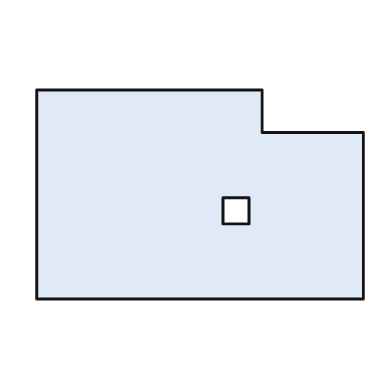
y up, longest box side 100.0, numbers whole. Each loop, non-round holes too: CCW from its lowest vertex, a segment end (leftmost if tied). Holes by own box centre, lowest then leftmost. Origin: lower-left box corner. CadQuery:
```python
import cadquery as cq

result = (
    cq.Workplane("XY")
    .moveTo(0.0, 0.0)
    .lineTo(100.0, 0.0)
    .lineTo(100.0, 51.0)
    .lineTo(69.0, 51.0)
    .lineTo(69.0, 64.0)
    .lineTo(0.0, 64.0)
    .close()
    .moveTo(57.0, 23.0)
    .lineTo(65.0, 23.0)
    .lineTo(65.0, 31.0)
    .lineTo(57.0, 31.0)
    .close()
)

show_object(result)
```